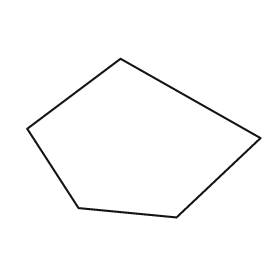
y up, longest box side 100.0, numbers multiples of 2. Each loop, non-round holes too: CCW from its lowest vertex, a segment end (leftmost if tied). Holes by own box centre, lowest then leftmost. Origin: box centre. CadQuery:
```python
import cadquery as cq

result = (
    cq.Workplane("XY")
    .moveTo(14.0, -34.0)
    .lineTo(50.0, 0.0)
    .lineTo(-10.0, 34.0)
    .lineTo(-50.0, 4.0)
    .lineTo(-28.0, -30.0)
    .close()
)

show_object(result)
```